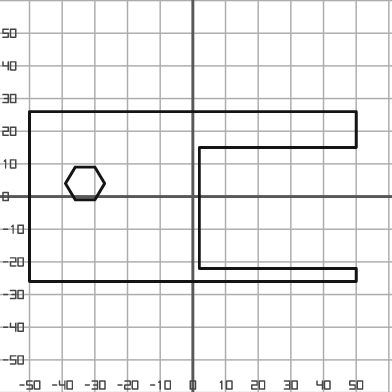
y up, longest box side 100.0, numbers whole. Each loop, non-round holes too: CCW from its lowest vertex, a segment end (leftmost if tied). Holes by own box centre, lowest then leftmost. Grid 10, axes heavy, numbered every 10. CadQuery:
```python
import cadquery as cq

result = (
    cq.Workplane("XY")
    .moveTo(-50.0, -26.0)
    .lineTo(50.0, -26.0)
    .lineTo(50.0, -22.0)
    .lineTo(2.0, -22.0)
    .lineTo(2.0, 15.0)
    .lineTo(50.0, 15.0)
    .lineTo(50.0, 26.0)
    .lineTo(-50.0, 26.0)
    .close()
    .moveTo(-36.0, -1.0)
    .lineTo(-30.0, -1.0)
    .lineTo(-27.0, 4.0)
    .lineTo(-30.0, 9.0)
    .lineTo(-36.0, 9.0)
    .lineTo(-39.0, 4.0)
    .close()
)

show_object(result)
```